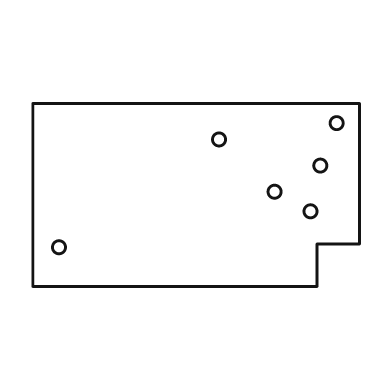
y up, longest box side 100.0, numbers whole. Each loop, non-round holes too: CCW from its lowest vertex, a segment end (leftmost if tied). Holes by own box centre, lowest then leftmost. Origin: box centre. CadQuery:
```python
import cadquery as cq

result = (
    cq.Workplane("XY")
    .moveTo(-50.0, -28.0)
    .lineTo(37.0, -28.0)
    .lineTo(37.0, -15.0)
    .lineTo(50.0, -15.0)
    .lineTo(50.0, 28.0)
    .lineTo(-50.0, 28.0)
    .close()
    .moveTo(-42.0, -16.0)
    .circle(2.0)
    .moveTo(35.0, -5.0)
    .circle(2.0)
    .moveTo(24.0, 1.0)
    .circle(2.0)
    .moveTo(38.0, 9.0)
    .circle(2.0)
    .moveTo(7.0, 17.0)
    .circle(2.0)
    .moveTo(43.0, 22.0)
    .circle(2.0)
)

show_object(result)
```